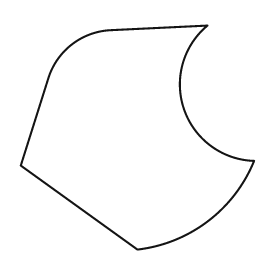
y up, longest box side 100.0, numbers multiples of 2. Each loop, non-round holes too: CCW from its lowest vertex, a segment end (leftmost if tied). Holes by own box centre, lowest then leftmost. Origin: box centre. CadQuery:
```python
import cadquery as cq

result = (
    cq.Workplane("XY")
    .moveTo(0.0, -48.0)
    .threePointArc((30.0, -36.0), (50.0, -10.0))
    .threePointArc((20.0, 12.0), (30.0, 48.0))
    .lineTo(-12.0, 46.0)
    .threePointArc((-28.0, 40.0), (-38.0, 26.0))
    .lineTo(-50.0, -12.0)
    .close()
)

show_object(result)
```